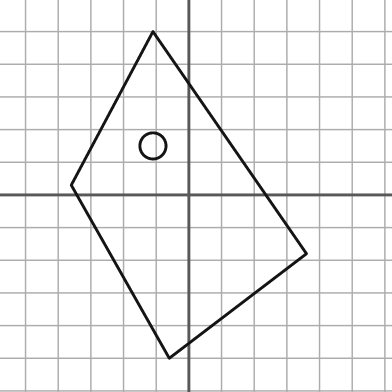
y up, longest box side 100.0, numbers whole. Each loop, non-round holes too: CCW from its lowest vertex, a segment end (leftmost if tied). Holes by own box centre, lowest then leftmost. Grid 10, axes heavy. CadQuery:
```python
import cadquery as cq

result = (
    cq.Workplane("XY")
    .moveTo(-6.0, -50.0)
    .lineTo(36.0, -18.0)
    .lineTo(-11.0, 50.0)
    .lineTo(-36.0, 3.0)
    .close()
    .moveTo(-11.0, 15.0)
    .circle(4.0)
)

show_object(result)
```